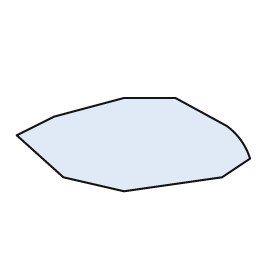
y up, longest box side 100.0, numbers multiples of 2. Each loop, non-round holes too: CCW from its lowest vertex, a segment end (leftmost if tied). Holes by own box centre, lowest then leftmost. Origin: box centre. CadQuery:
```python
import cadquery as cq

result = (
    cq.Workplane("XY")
    .moveTo(-4.0, -20.0)
    .lineTo(38.0, -14.0)
    .lineTo(50.0, -6.0)
    .threePointArc((46.0, 2.0), (40.0, 8.0))
    .lineTo(18.0, 20.0)
    .lineTo(-4.0, 20.0)
    .lineTo(-34.0, 12.0)
    .lineTo(-50.0, 4.0)
    .lineTo(-30.0, -14.0)
    .close()
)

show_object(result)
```